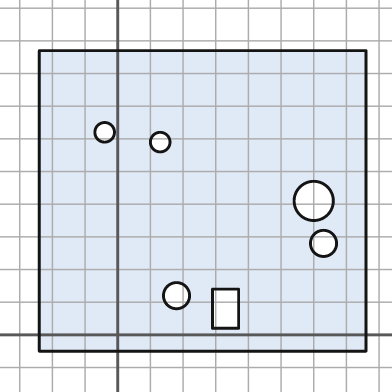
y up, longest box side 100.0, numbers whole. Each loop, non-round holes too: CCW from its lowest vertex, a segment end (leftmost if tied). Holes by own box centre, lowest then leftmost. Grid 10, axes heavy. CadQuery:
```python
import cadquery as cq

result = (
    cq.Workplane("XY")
    .moveTo(-24.0, -5.0)
    .lineTo(76.0, -5.0)
    .lineTo(76.0, 87.0)
    .lineTo(-24.0, 87.0)
    .close()
    .moveTo(29.0, 2.0)
    .lineTo(37.0, 2.0)
    .lineTo(37.0, 14.0)
    .lineTo(29.0, 14.0)
    .close()
    .moveTo(18.0, 12.0)
    .circle(4.0)
    .moveTo(63.0, 28.0)
    .circle(4.0)
    .moveTo(60.0, 41.0)
    .circle(6.0)
    .moveTo(13.0, 59.0)
    .circle(3.0)
    .moveTo(-4.0, 62.0)
    .circle(3.0)
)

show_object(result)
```